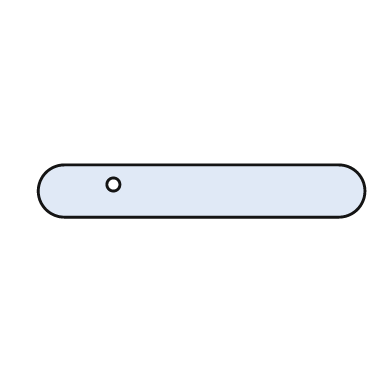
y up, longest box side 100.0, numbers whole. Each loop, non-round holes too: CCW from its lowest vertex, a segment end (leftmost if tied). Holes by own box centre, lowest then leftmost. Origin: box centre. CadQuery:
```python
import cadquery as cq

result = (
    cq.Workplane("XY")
    .moveTo(-42.0, -8.0)
    .lineTo(42.0, -8.0)
    .threePointArc((50.0, 0.0), (42.0, 8.0))
    .lineTo(-42.0, 8.0)
    .threePointArc((-50.0, 0.0), (-42.0, -8.0))
    .close()
    .moveTo(-27.0, 2.0)
    .circle(2.0)
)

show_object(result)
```